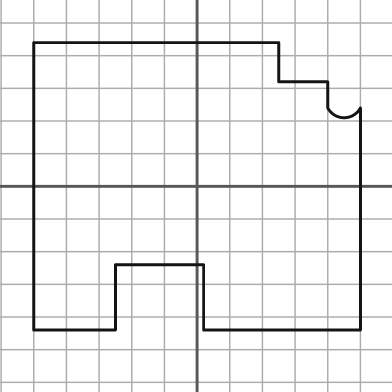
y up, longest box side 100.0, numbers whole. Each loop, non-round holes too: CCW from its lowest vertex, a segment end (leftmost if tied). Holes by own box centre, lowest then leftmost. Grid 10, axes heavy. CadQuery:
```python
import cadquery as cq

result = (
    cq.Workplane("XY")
    .moveTo(-50.0, -44.0)
    .lineTo(-25.0, -44.0)
    .lineTo(-25.0, -24.0)
    .lineTo(2.0, -24.0)
    .lineTo(2.0, -44.0)
    .lineTo(50.0, -44.0)
    .lineTo(50.0, 24.0)
    .threePointArc((45.0, 21.0), (40.0, 24.0))
    .lineTo(40.0, 32.0)
    .lineTo(25.0, 32.0)
    .lineTo(25.0, 44.0)
    .lineTo(-50.0, 44.0)
    .close()
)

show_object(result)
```